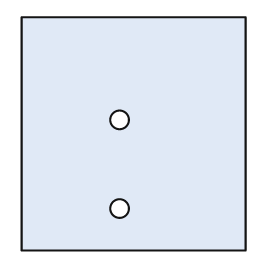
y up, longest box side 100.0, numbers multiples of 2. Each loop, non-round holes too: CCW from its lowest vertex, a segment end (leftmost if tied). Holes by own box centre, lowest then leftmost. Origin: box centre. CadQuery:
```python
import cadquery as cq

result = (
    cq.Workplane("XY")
    .moveTo(-48.0, -50.0)
    .lineTo(48.0, -50.0)
    .lineTo(48.0, 50.0)
    .lineTo(-48.0, 50.0)
    .close()
    .moveTo(-6.0, -32.0)
    .circle(4.0)
    .moveTo(-6.0, 6.0)
    .circle(4.0)
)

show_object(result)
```